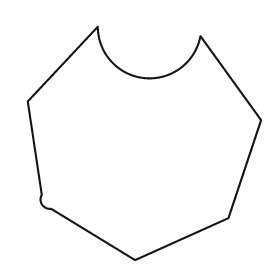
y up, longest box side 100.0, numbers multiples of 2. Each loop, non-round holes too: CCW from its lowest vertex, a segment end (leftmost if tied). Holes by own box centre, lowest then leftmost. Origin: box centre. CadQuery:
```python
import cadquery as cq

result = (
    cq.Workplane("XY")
    .moveTo(-4.0, -50.0)
    .lineTo(36.0, -32.0)
    .lineTo(50.0, 10.0)
    .lineTo(24.0, 46.0)
    .threePointArc((0.0, 28.0), (-20.0, 50.0))
    .lineTo(-50.0, 18.0)
    .lineTo(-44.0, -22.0)
    .threePointArc((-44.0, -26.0), (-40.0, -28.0))
    .close()
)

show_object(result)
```